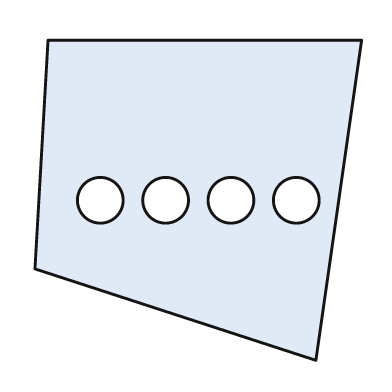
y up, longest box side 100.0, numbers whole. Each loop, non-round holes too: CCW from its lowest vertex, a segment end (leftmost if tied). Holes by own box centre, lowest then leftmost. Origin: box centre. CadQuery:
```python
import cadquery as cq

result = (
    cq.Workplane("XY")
    .moveTo(36.0, -49.0)
    .lineTo(50.0, 49.0)
    .lineTo(-46.0, 49.0)
    .lineTo(-50.0, -21.0)
    .close()
    .moveTo(-30.0, 0.0)
    .circle(7.0)
    .moveTo(-10.0, 0.0)
    .circle(7.0)
    .moveTo(10.0, 0.0)
    .circle(7.0)
    .moveTo(30.0, 0.0)
    .circle(7.0)
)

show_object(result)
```